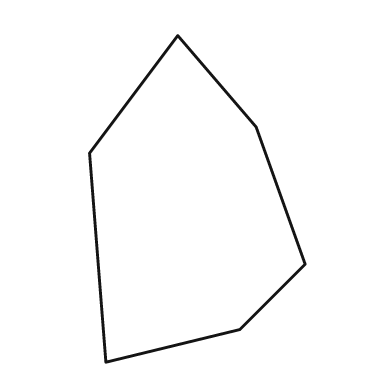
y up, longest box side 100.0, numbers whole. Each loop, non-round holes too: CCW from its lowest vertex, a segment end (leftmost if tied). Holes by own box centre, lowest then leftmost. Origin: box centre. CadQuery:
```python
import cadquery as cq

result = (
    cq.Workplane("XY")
    .moveTo(-28.0, -50.0)
    .lineTo(13.0, -40.0)
    .lineTo(33.0, -20.0)
    .lineTo(18.0, 22.0)
    .lineTo(-6.0, 50.0)
    .lineTo(-33.0, 14.0)
    .close()
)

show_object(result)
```